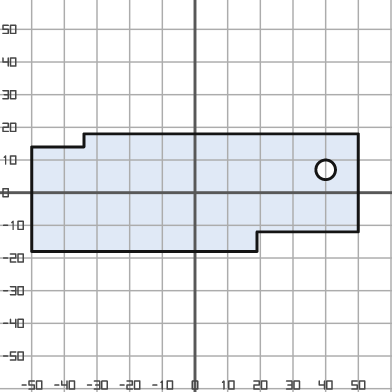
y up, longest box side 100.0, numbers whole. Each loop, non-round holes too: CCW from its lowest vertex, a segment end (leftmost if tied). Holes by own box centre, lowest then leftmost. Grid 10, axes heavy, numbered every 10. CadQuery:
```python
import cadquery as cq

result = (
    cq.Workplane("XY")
    .moveTo(-50.0, -18.0)
    .lineTo(19.0, -18.0)
    .lineTo(19.0, -12.0)
    .lineTo(50.0, -12.0)
    .lineTo(50.0, 18.0)
    .lineTo(-34.0, 18.0)
    .lineTo(-34.0, 14.0)
    .lineTo(-50.0, 14.0)
    .close()
    .moveTo(40.0, 7.0)
    .circle(3.0)
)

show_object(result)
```